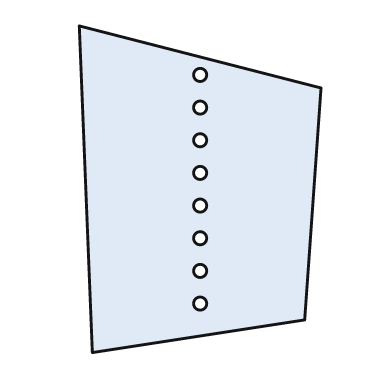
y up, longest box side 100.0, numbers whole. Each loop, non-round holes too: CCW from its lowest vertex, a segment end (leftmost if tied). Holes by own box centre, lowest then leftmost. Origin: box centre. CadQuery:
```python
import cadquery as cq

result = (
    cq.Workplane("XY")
    .moveTo(-33.0, -50.0)
    .lineTo(32.0, -40.0)
    .lineTo(37.0, 31.0)
    .lineTo(-37.0, 50.0)
    .close()
    .moveTo(0.0, -35.0)
    .circle(2.0)
    .moveTo(0.0, -25.0)
    .circle(2.0)
    .moveTo(0.0, -15.0)
    .circle(2.0)
    .moveTo(0.0, -5.0)
    .circle(2.0)
    .moveTo(0.0, 5.0)
    .circle(2.0)
    .moveTo(0.0, 15.0)
    .circle(2.0)
    .moveTo(0.0, 25.0)
    .circle(2.0)
    .moveTo(0.0, 35.0)
    .circle(2.0)
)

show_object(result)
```